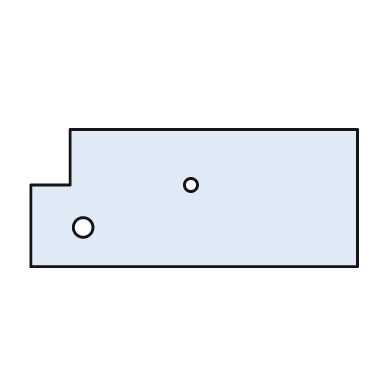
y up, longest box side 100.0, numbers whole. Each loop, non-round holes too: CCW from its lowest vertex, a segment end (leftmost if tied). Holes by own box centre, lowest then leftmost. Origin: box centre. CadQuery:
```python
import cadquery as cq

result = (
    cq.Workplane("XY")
    .moveTo(-50.0, -21.0)
    .lineTo(50.0, -21.0)
    .lineTo(50.0, 21.0)
    .lineTo(-38.0, 21.0)
    .lineTo(-38.0, 4.0)
    .lineTo(-50.0, 4.0)
    .close()
    .moveTo(-34.0, -9.0)
    .circle(3.0)
    .moveTo(-1.0, 4.0)
    .circle(2.0)
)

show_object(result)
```